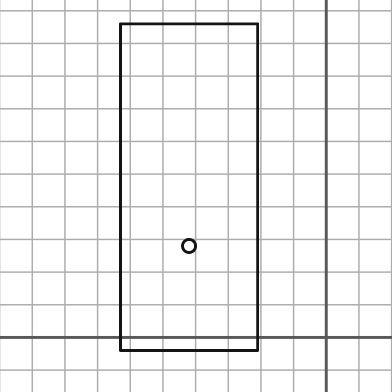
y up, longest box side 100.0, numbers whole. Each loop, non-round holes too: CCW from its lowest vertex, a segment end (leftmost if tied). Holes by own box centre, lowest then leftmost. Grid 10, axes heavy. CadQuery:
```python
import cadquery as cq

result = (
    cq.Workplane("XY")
    .moveTo(-63.0, -4.0)
    .lineTo(-21.0, -4.0)
    .lineTo(-21.0, 96.0)
    .lineTo(-63.0, 96.0)
    .close()
    .moveTo(-42.0, 28.0)
    .circle(2.0)
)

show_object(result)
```